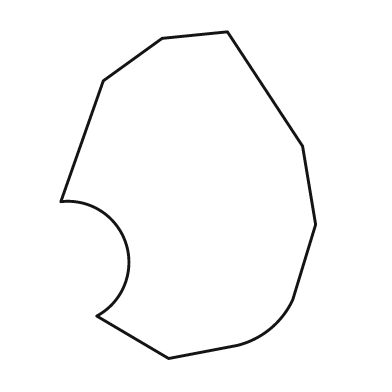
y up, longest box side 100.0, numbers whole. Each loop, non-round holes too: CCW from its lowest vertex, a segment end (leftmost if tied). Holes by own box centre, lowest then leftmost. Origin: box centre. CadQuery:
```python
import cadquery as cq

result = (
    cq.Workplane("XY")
    .moveTo(-6.0, -50.0)
    .lineTo(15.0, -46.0)
    .threePointArc((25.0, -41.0), (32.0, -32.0))
    .lineTo(39.0, -9.0)
    .lineTo(35.0, 15.0)
    .lineTo(12.0, 50.0)
    .lineTo(-8.0, 48.0)
    .lineTo(-26.0, 35.0)
    .lineTo(-39.0, -2.0)
    .threePointArc((-19.0, -15.0), (-28.0, -37.0))
    .close()
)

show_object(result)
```